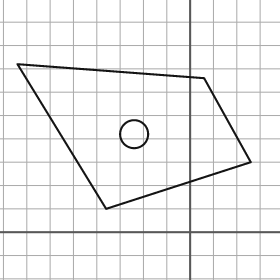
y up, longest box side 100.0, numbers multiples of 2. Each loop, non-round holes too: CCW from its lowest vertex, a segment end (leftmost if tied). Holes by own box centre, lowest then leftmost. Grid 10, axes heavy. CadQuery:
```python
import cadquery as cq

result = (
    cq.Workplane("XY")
    .moveTo(-36.0, 10.0)
    .lineTo(26.0, 30.0)
    .lineTo(6.0, 66.0)
    .lineTo(-74.0, 72.0)
    .close()
    .moveTo(-24.0, 42.0)
    .circle(6.0)
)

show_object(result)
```